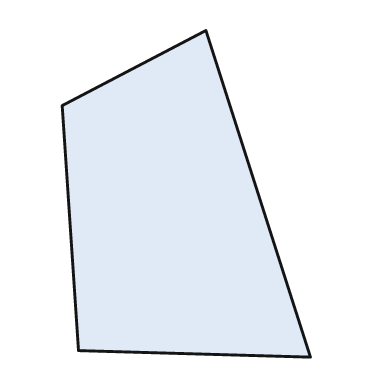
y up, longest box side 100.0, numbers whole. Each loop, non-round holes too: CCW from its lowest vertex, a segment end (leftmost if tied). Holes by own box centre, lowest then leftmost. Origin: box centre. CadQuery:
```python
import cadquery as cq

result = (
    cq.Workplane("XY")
    .moveTo(38.0, -50.0)
    .lineTo(6.0, 50.0)
    .lineTo(-38.0, 27.0)
    .lineTo(-33.0, -48.0)
    .close()
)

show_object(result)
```